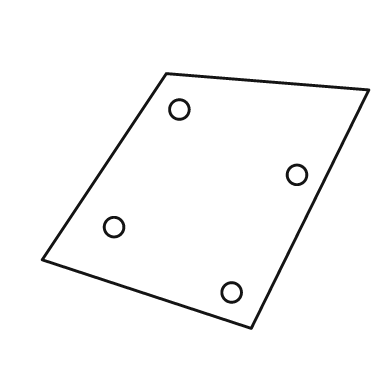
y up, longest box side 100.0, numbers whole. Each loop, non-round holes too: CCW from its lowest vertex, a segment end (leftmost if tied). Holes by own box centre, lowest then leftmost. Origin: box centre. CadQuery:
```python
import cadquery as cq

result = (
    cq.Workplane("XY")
    .moveTo(14.0, -39.0)
    .lineTo(50.0, 34.0)
    .lineTo(-12.0, 39.0)
    .lineTo(-50.0, -18.0)
    .close()
    .moveTo(8.0, -28.0)
    .circle(3.0)
    .moveTo(-28.0, -8.0)
    .circle(3.0)
    .moveTo(28.0, 8.0)
    .circle(3.0)
    .moveTo(-8.0, 28.0)
    .circle(3.0)
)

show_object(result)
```